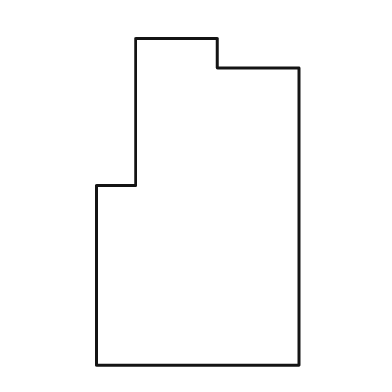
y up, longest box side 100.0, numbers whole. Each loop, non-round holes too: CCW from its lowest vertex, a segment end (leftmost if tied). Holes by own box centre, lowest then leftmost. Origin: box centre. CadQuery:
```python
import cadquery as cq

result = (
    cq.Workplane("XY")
    .moveTo(-31.0, -50.0)
    .lineTo(31.0, -50.0)
    .lineTo(31.0, 41.0)
    .lineTo(6.0, 41.0)
    .lineTo(6.0, 50.0)
    .lineTo(-19.0, 50.0)
    .lineTo(-19.0, 5.0)
    .lineTo(-31.0, 5.0)
    .close()
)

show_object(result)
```